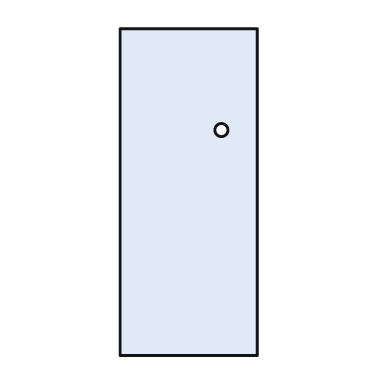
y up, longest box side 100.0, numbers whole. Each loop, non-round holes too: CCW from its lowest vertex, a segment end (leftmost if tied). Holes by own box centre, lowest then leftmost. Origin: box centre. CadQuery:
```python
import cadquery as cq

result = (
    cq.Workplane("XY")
    .moveTo(-21.0, -50.0)
    .lineTo(21.0, -50.0)
    .lineTo(21.0, 50.0)
    .lineTo(-21.0, 50.0)
    .close()
    .moveTo(10.0, 19.0)
    .circle(2.0)
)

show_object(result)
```